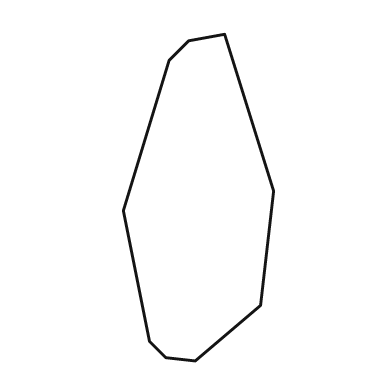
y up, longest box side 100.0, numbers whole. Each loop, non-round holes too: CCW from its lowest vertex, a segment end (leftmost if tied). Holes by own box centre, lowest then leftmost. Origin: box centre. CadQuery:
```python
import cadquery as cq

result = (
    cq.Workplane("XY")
    .moveTo(-1.0, -50.0)
    .lineTo(19.0, -33.0)
    .lineTo(23.0, 2.0)
    .lineTo(8.0, 50.0)
    .lineTo(-3.0, 48.0)
    .lineTo(-9.0, 42.0)
    .lineTo(-23.0, -4.0)
    .lineTo(-15.0, -44.0)
    .lineTo(-10.0, -49.0)
    .close()
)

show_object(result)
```